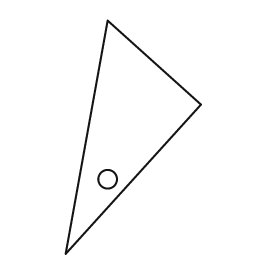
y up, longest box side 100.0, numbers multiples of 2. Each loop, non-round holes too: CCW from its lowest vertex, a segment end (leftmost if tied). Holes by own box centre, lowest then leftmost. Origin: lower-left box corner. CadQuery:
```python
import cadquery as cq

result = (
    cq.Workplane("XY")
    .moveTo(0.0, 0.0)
    .lineTo(58.0, 64.0)
    .lineTo(18.0, 100.0)
    .close()
    .moveTo(18.0, 32.0)
    .circle(4.0)
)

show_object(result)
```